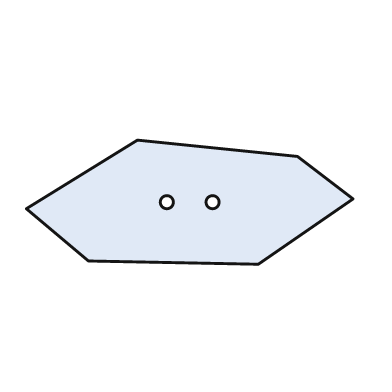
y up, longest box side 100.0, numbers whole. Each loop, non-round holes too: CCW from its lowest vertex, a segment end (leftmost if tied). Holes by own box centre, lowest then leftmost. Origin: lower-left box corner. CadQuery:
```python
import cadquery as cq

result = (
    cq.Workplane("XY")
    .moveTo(71.0, 0.0)
    .lineTo(100.0, 20.0)
    .lineTo(83.0, 33.0)
    .lineTo(34.0, 38.0)
    .lineTo(0.0, 17.0)
    .lineTo(19.0, 1.0)
    .close()
    .moveTo(43.0, 19.0)
    .circle(2.0)
    .moveTo(57.0, 19.0)
    .circle(2.0)
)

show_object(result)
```